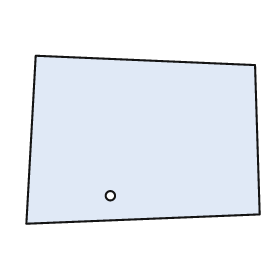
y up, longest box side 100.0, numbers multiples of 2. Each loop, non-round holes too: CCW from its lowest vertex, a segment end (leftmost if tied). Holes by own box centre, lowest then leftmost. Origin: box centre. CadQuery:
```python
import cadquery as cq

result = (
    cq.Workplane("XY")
    .moveTo(-50.0, -36.0)
    .lineTo(50.0, -32.0)
    .lineTo(48.0, 32.0)
    .lineTo(-46.0, 36.0)
    .close()
    .moveTo(-14.0, -24.0)
    .circle(2.0)
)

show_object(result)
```